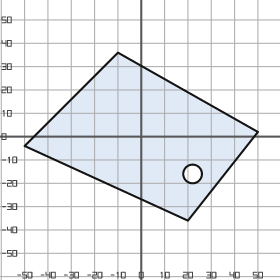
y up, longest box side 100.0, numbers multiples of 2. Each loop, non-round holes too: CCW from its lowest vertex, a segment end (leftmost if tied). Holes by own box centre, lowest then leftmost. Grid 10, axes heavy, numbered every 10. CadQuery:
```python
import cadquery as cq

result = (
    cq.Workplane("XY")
    .moveTo(20.0, -36.0)
    .lineTo(50.0, 2.0)
    .lineTo(-10.0, 36.0)
    .lineTo(-50.0, -4.0)
    .close()
    .moveTo(22.0, -16.0)
    .circle(4.0)
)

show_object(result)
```